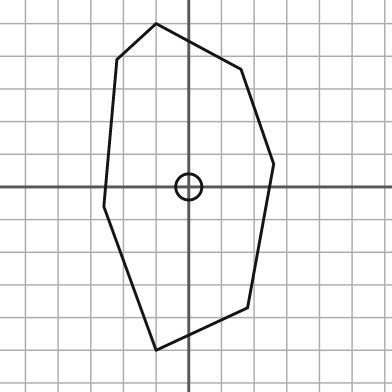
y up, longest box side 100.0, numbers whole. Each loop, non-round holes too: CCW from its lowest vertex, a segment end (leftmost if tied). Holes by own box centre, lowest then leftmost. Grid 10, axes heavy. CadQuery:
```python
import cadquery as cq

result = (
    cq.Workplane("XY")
    .moveTo(-10.0, -50.0)
    .lineTo(18.0, -37.0)
    .lineTo(26.0, 7.0)
    .lineTo(16.0, 36.0)
    .lineTo(-10.0, 50.0)
    .lineTo(-22.0, 39.0)
    .lineTo(-26.0, -6.0)
    .close()
    .moveTo(0.0, 0.0)
    .circle(4.0)
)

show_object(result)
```